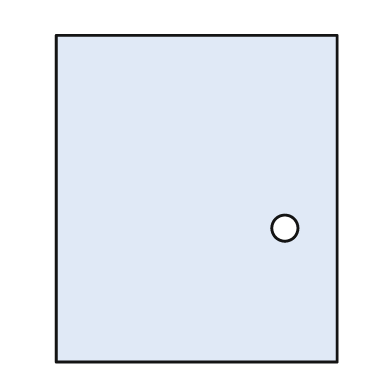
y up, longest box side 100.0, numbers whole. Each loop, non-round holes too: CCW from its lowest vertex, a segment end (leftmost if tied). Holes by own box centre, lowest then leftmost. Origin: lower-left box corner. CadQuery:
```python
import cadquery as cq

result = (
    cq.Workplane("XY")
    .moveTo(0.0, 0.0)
    .lineTo(86.0, 0.0)
    .lineTo(86.0, 100.0)
    .lineTo(0.0, 100.0)
    .close()
    .moveTo(70.0, 41.0)
    .circle(4.0)
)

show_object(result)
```